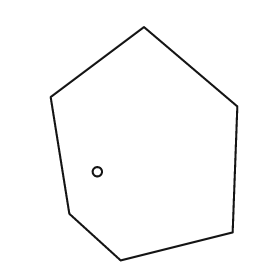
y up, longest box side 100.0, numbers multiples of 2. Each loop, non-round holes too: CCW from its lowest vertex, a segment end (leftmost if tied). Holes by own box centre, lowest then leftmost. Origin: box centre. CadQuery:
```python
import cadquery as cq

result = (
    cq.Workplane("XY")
    .moveTo(-10.0, -50.0)
    .lineTo(38.0, -38.0)
    .lineTo(40.0, 16.0)
    .lineTo(0.0, 50.0)
    .lineTo(-40.0, 20.0)
    .lineTo(-32.0, -30.0)
    .close()
    .moveTo(-20.0, -12.0)
    .circle(2.0)
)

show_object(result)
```